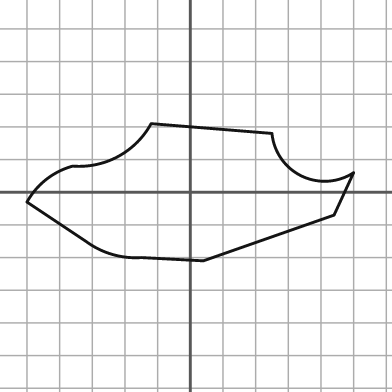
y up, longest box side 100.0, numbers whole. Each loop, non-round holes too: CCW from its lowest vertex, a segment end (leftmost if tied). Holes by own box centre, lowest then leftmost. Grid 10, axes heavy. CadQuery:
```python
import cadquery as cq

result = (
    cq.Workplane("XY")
    .moveTo(4.0, -21.0)
    .lineTo(44.0, -7.0)
    .lineTo(50.0, 6.0)
    .threePointArc((34.0, 5.0), (25.0, 18.0))
    .lineTo(-12.0, 21.0)
    .threePointArc((-22.0, 11.0), (-36.0, 8.0))
    .threePointArc((-44.0, 4.0), (-50.0, -3.0))
    .lineTo(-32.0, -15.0)
    .threePointArc((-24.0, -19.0), (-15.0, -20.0))
    .close()
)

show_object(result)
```